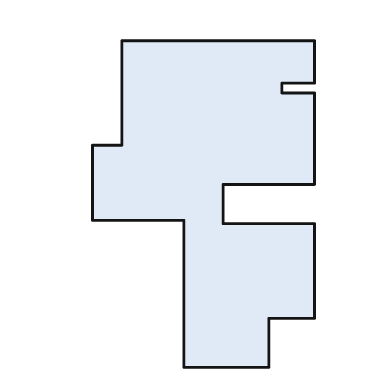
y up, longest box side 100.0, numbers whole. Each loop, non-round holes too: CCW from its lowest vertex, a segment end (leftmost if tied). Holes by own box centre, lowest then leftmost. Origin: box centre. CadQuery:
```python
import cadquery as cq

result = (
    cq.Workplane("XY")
    .moveTo(-6.0, -50.0)
    .lineTo(20.0, -50.0)
    .lineTo(20.0, -35.0)
    .lineTo(34.0, -35.0)
    .lineTo(34.0, -6.0)
    .lineTo(6.0, -6.0)
    .lineTo(6.0, 6.0)
    .lineTo(34.0, 6.0)
    .lineTo(34.0, 34.0)
    .lineTo(24.0, 34.0)
    .lineTo(24.0, 37.0)
    .lineTo(34.0, 37.0)
    .lineTo(34.0, 50.0)
    .lineTo(-25.0, 50.0)
    .lineTo(-25.0, 18.0)
    .lineTo(-34.0, 18.0)
    .lineTo(-34.0, -5.0)
    .lineTo(-6.0, -5.0)
    .close()
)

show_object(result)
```